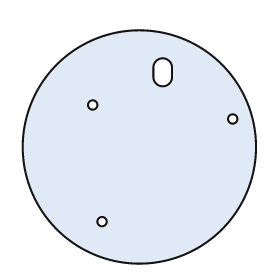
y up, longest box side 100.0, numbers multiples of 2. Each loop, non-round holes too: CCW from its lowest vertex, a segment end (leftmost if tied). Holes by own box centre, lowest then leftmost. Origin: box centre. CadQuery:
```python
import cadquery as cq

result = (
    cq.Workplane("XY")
    .moveTo(0.0, 0.0)
    .circle(50.0)
    .moveTo(-16.0, -32.0)
    .circle(2.0)
    .moveTo(40.0, 12.0)
    .circle(2.0)
    .moveTo(-20.0, 18.0)
    .circle(2.0)
    .moveTo(6.0, 30.0)
    .threePointArc((10.0, 26.0), (14.0, 30.0))
    .lineTo(14.0, 34.0)
    .threePointArc((10.0, 38.0), (6.0, 34.0))
    .close()
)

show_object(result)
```